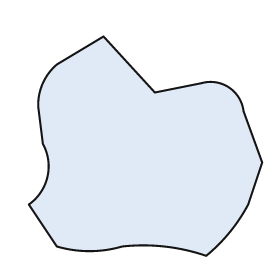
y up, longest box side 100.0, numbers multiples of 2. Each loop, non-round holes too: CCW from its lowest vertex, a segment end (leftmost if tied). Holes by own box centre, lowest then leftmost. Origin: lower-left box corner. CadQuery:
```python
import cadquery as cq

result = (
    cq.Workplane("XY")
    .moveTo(76.0, 0.0)
    .threePointArc((86.0, 10.0), (94.0, 22.0))
    .lineTo(100.0, 40.0)
    .lineTo(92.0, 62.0)
    .threePointArc((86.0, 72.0), (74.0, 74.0))
    .lineTo(54.0, 70.0)
    .lineTo(32.0, 94.0)
    .lineTo(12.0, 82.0)
    .threePointArc((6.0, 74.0), (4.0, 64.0))
    .lineTo(6.0, 48.0)
    .threePointArc((8.0, 34.0), (0.0, 22.0))
    .lineTo(12.0, 4.0)
    .threePointArc((26.0, 2.0), (40.0, 4.0))
    .threePointArc((58.0, 4.0), (76.0, 0.0))
    .close()
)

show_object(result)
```